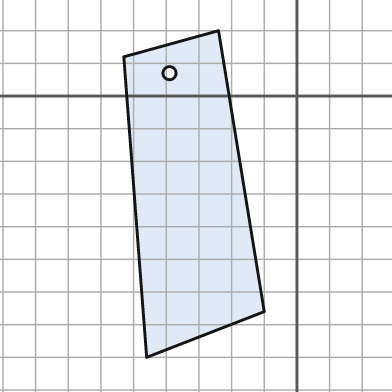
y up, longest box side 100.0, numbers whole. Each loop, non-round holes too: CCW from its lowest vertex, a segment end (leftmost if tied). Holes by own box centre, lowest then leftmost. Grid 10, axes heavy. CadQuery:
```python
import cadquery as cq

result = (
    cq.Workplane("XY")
    .moveTo(-46.0, -80.0)
    .lineTo(-10.0, -66.0)
    .lineTo(-24.0, 20.0)
    .lineTo(-53.0, 12.0)
    .close()
    .moveTo(-39.0, 7.0)
    .circle(2.0)
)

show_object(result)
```